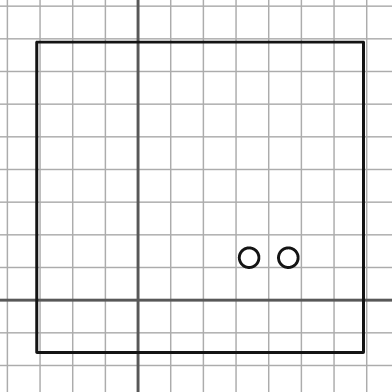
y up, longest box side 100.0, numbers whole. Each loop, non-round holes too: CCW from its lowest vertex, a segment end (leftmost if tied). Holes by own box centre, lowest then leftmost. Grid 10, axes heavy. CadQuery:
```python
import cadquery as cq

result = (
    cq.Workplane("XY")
    .moveTo(-31.0, -16.0)
    .lineTo(69.0, -16.0)
    .lineTo(69.0, 79.0)
    .lineTo(-31.0, 79.0)
    .close()
    .moveTo(34.0, 13.0)
    .circle(3.0)
    .moveTo(46.0, 13.0)
    .circle(3.0)
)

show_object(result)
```